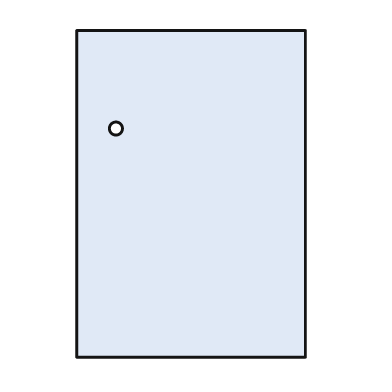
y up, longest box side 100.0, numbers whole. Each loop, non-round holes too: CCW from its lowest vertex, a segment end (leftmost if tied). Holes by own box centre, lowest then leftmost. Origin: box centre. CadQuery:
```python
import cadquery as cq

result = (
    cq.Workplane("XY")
    .moveTo(-35.0, -50.0)
    .lineTo(35.0, -50.0)
    .lineTo(35.0, 50.0)
    .lineTo(-35.0, 50.0)
    .close()
    .moveTo(-23.0, 20.0)
    .circle(2.0)
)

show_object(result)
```